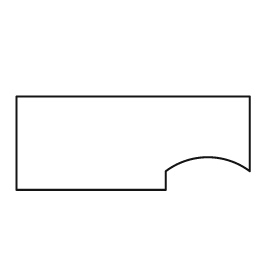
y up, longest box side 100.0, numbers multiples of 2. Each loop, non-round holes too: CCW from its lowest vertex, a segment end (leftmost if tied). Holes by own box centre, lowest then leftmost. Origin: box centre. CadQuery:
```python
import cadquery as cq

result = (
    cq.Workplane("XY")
    .moveTo(-50.0, -20.0)
    .lineTo(14.0, -20.0)
    .lineTo(14.0, -12.0)
    .threePointArc((32.0, -6.0), (50.0, -12.0))
    .lineTo(50.0, 20.0)
    .lineTo(-50.0, 20.0)
    .close()
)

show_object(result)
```